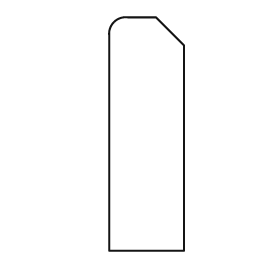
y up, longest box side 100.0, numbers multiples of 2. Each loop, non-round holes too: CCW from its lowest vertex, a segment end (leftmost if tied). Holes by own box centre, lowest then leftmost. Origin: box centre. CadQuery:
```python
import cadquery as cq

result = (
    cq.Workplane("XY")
    .moveTo(-16.0, -50.0)
    .lineTo(16.0, -50.0)
    .lineTo(16.0, 38.0)
    .lineTo(4.0, 50.0)
    .lineTo(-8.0, 50.0)
    .threePointArc((-14.0, 48.0), (-16.0, 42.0))
    .close()
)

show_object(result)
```